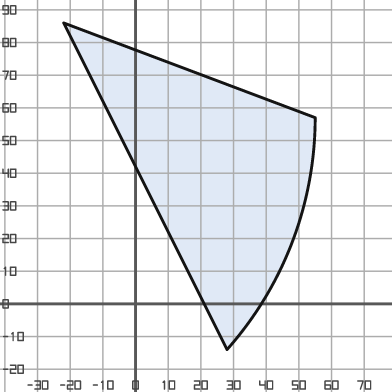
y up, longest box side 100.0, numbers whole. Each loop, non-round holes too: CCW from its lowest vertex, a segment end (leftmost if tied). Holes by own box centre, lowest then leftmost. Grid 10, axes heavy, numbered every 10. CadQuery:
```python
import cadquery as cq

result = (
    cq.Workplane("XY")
    .moveTo(28.0, -14.0)
    .threePointArc((48.0, 19.0), (55.0, 57.0))
    .lineTo(-22.0, 86.0)
    .close()
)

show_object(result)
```